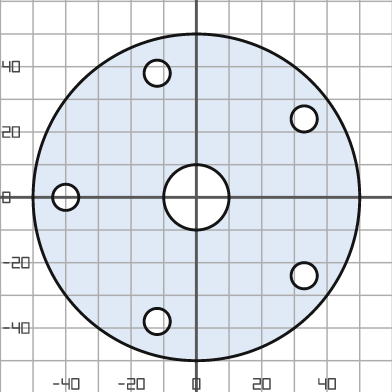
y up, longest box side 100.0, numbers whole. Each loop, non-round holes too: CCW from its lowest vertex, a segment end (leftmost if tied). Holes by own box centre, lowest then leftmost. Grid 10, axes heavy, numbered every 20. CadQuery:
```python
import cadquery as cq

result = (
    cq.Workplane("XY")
    .moveTo(0.0, 0.0)
    .circle(50.0)
    .moveTo(-12.0, -38.0)
    .circle(4.0)
    .moveTo(33.0, -24.0)
    .circle(4.0)
    .moveTo(-40.0, 0.0)
    .circle(4.0)
    .moveTo(0.0, 0.0)
    .circle(10.0)
    .moveTo(33.0, 24.0)
    .circle(4.0)
    .moveTo(-12.0, 38.0)
    .circle(4.0)
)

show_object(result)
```